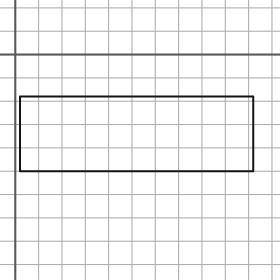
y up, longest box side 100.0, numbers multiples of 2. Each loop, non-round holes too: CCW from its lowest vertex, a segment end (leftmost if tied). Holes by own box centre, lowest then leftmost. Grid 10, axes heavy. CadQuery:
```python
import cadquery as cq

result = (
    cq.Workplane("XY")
    .moveTo(2.0, -50.0)
    .lineTo(102.0, -50.0)
    .lineTo(102.0, -18.0)
    .lineTo(2.0, -18.0)
    .close()
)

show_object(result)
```